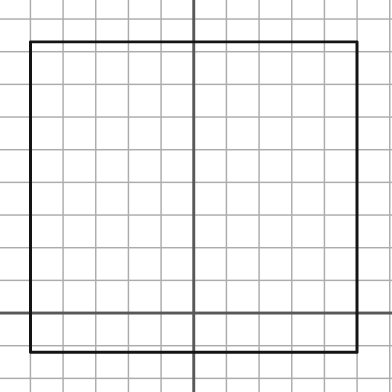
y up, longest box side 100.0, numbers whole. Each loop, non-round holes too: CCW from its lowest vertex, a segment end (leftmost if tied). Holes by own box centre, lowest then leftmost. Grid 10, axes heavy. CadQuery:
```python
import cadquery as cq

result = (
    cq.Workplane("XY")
    .moveTo(-50.0, -12.0)
    .lineTo(50.0, -12.0)
    .lineTo(50.0, 83.0)
    .lineTo(-50.0, 83.0)
    .close()
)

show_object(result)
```